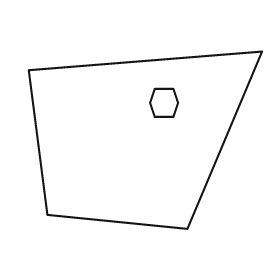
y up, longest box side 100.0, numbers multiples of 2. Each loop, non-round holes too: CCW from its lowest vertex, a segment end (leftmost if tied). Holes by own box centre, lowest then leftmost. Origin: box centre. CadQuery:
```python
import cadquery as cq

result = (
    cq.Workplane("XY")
    .moveTo(18.0, -38.0)
    .lineTo(50.0, 38.0)
    .lineTo(-50.0, 30.0)
    .lineTo(-42.0, -32.0)
    .close()
    .moveTo(4.0, 10.0)
    .lineTo(12.0, 10.0)
    .lineTo(14.0, 16.0)
    .lineTo(12.0, 22.0)
    .lineTo(4.0, 22.0)
    .lineTo(2.0, 16.0)
    .close()
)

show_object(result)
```